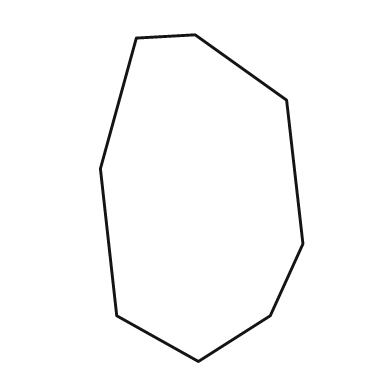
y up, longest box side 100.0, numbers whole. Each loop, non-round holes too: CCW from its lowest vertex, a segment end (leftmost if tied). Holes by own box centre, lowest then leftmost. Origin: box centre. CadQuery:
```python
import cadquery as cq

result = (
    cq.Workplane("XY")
    .moveTo(-1.0, -50.0)
    .lineTo(21.0, -36.0)
    .lineTo(31.0, -14.0)
    .lineTo(26.0, 30.0)
    .lineTo(-2.0, 50.0)
    .lineTo(-20.0, 49.0)
    .lineTo(-31.0, 9.0)
    .lineTo(-26.0, -36.0)
    .close()
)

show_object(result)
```